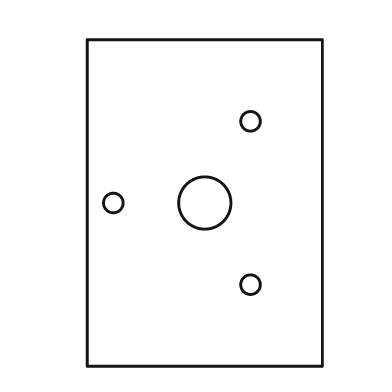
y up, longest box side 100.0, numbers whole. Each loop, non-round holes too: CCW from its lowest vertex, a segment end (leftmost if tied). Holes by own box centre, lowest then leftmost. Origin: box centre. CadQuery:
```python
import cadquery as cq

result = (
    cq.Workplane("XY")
    .moveTo(-36.0, -50.0)
    .lineTo(36.0, -50.0)
    .lineTo(36.0, 50.0)
    .lineTo(-36.0, 50.0)
    .close()
    .moveTo(14.0, -25.0)
    .circle(3.0)
    .moveTo(-28.0, 0.0)
    .circle(3.0)
    .moveTo(0.0, 0.0)
    .circle(8.0)
    .moveTo(14.0, 25.0)
    .circle(3.0)
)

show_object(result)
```